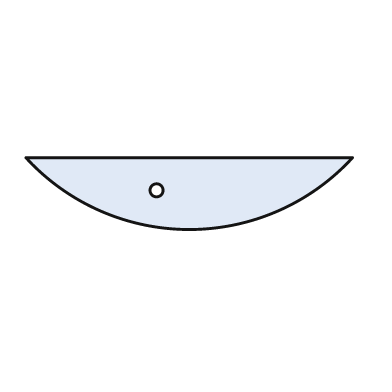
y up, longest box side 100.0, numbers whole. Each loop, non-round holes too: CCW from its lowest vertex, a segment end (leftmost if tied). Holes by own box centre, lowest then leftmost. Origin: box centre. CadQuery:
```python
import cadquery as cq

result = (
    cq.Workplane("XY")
    .moveTo(-50.0, 11.0)
    .threePointArc((0.0, -11.0), (50.0, 11.0))
    .close()
    .moveTo(-10.0, 1.0)
    .circle(2.0)
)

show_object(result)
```